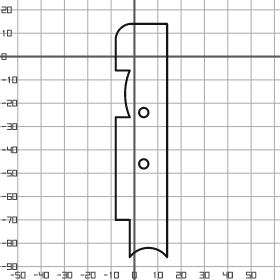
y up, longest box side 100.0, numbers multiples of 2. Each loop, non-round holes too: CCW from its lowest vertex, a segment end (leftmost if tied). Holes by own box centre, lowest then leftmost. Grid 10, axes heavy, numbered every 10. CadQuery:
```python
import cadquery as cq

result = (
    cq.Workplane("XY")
    .moveTo(-2.0, -86.0)
    .threePointArc((6.0, -82.0), (14.0, -86.0))
    .lineTo(14.0, 14.0)
    .lineTo(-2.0, 14.0)
    .threePointArc((-6.0, 12.0), (-8.0, 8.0))
    .lineTo(-8.0, -6.0)
    .lineTo(-2.0, -6.0)
    .threePointArc((-4.0, -16.0), (-2.0, -26.0))
    .lineTo(-8.0, -26.0)
    .lineTo(-8.0, -70.0)
    .lineTo(-2.0, -70.0)
    .close()
    .moveTo(4.0, -46.0)
    .circle(2.0)
    .moveTo(4.0, -24.0)
    .circle(2.0)
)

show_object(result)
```